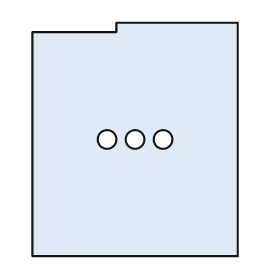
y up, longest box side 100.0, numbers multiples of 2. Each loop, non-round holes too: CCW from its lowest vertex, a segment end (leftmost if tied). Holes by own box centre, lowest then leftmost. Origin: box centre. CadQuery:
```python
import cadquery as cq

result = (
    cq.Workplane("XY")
    .moveTo(-44.0, -50.0)
    .lineTo(44.0, -50.0)
    .lineTo(44.0, 50.0)
    .lineTo(-8.0, 50.0)
    .lineTo(-8.0, 46.0)
    .lineTo(-44.0, 46.0)
    .close()
    .moveTo(-12.0, 0.0)
    .circle(4.0)
    .moveTo(0.0, 0.0)
    .circle(4.0)
    .moveTo(12.0, 0.0)
    .circle(4.0)
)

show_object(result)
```